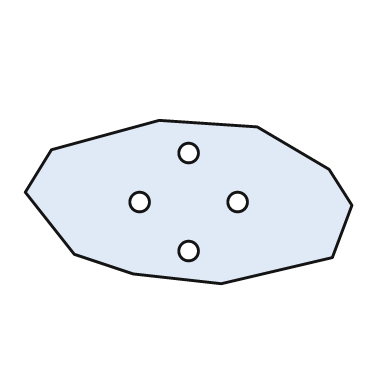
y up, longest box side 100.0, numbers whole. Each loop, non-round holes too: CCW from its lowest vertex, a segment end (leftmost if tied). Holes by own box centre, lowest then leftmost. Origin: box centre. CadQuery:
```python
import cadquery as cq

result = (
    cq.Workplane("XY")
    .moveTo(10.0, -25.0)
    .lineTo(44.0, -17.0)
    .lineTo(50.0, -1.0)
    .lineTo(43.0, 10.0)
    .lineTo(21.0, 23.0)
    .lineTo(-9.0, 25.0)
    .lineTo(-42.0, 16.0)
    .lineTo(-50.0, 3.0)
    .lineTo(-35.0, -16.0)
    .lineTo(-17.0, -22.0)
    .close()
    .moveTo(0.0, -15.0)
    .circle(3.0)
    .moveTo(-15.0, 0.0)
    .circle(3.0)
    .moveTo(15.0, 0.0)
    .circle(3.0)
    .moveTo(0.0, 15.0)
    .circle(3.0)
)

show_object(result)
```